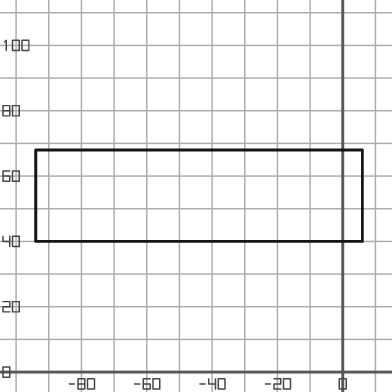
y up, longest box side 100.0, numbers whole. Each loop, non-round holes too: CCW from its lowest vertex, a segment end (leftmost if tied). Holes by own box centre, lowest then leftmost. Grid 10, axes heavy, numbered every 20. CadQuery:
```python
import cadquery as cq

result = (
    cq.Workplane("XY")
    .moveTo(-94.0, 40.0)
    .lineTo(6.0, 40.0)
    .lineTo(6.0, 68.0)
    .lineTo(-94.0, 68.0)
    .close()
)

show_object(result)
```